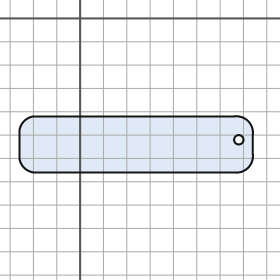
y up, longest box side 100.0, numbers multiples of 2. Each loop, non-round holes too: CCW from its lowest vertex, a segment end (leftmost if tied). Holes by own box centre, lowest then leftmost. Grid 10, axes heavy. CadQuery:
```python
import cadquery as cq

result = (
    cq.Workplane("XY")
    .moveTo(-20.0, -66.0)
    .lineTo(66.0, -66.0)
    .threePointArc((72.0, -64.0), (74.0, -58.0))
    .lineTo(74.0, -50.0)
    .threePointArc((72.0, -44.0), (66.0, -42.0))
    .lineTo(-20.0, -42.0)
    .threePointArc((-24.0, -44.0), (-26.0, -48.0))
    .lineTo(-26.0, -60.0)
    .threePointArc((-24.0, -64.0), (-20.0, -66.0))
    .close()
    .moveTo(68.0, -52.0)
    .circle(2.0)
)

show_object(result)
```